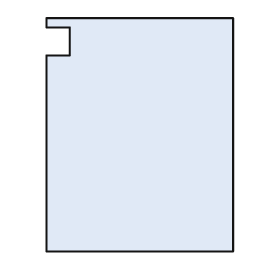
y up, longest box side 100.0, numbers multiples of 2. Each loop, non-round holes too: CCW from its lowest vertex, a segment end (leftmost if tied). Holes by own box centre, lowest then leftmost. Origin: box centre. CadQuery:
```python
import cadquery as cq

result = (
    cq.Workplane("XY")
    .moveTo(-40.0, -50.0)
    .lineTo(40.0, -50.0)
    .lineTo(40.0, 50.0)
    .lineTo(-40.0, 50.0)
    .lineTo(-40.0, 46.0)
    .lineTo(-30.0, 46.0)
    .lineTo(-30.0, 34.0)
    .lineTo(-40.0, 34.0)
    .close()
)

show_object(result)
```